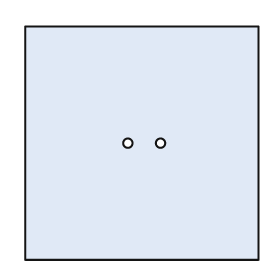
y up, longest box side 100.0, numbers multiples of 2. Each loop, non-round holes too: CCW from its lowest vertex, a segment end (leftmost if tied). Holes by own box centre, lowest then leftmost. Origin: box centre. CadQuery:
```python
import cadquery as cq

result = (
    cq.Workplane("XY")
    .moveTo(-50.0, -50.0)
    .lineTo(50.0, -50.0)
    .lineTo(50.0, 50.0)
    .lineTo(-50.0, 50.0)
    .close()
    .moveTo(-6.0, 0.0)
    .circle(2.0)
    .moveTo(8.0, 0.0)
    .circle(2.0)
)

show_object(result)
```